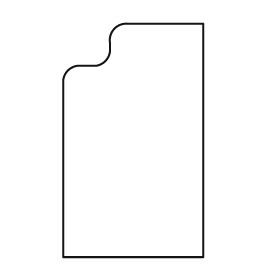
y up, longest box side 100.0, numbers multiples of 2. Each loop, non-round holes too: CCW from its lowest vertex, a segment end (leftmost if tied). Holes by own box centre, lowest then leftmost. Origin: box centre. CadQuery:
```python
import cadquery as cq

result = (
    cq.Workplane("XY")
    .moveTo(-30.0, -50.0)
    .lineTo(30.0, -50.0)
    .lineTo(30.0, 50.0)
    .lineTo(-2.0, 50.0)
    .threePointArc((-8.0, 48.0), (-10.0, 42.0))
    .lineTo(-10.0, 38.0)
    .threePointArc((-12.0, 34.0), (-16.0, 32.0))
    .lineTo(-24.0, 32.0)
    .threePointArc((-28.0, 30.0), (-30.0, 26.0))
    .close()
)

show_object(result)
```